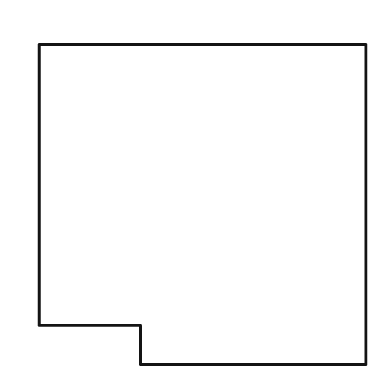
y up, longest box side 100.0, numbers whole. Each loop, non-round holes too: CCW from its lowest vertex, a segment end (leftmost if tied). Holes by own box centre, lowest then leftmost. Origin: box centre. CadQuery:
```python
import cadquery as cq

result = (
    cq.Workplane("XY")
    .moveTo(-19.0, -49.0)
    .lineTo(50.0, -49.0)
    .lineTo(50.0, 49.0)
    .lineTo(-50.0, 49.0)
    .lineTo(-50.0, -37.0)
    .lineTo(-19.0, -37.0)
    .close()
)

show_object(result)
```